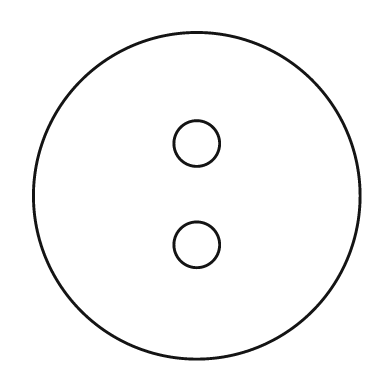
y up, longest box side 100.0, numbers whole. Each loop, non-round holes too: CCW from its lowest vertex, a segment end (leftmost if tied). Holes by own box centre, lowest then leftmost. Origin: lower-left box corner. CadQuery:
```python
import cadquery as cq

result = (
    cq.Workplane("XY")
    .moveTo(50.0, 50.0)
    .circle(50.0)
    .moveTo(50.0, 35.0)
    .circle(7.0)
    .moveTo(50.0, 66.0)
    .circle(7.0)
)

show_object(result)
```